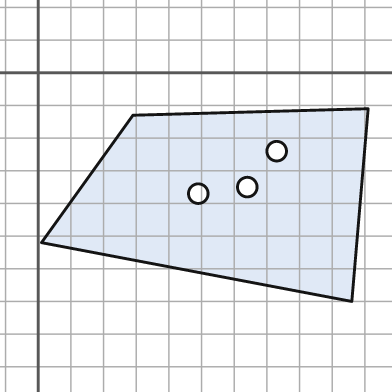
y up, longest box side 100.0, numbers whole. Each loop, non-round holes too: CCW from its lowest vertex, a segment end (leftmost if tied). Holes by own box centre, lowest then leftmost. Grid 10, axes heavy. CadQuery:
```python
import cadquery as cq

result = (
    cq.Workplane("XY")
    .moveTo(96.0, -70.0)
    .lineTo(101.0, -11.0)
    .lineTo(29.0, -13.0)
    .lineTo(1.0, -52.0)
    .close()
    .moveTo(49.0, -37.0)
    .circle(3.0)
    .moveTo(64.0, -35.0)
    .circle(3.0)
    .moveTo(73.0, -24.0)
    .circle(3.0)
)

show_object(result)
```